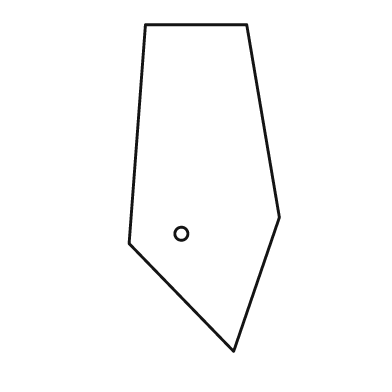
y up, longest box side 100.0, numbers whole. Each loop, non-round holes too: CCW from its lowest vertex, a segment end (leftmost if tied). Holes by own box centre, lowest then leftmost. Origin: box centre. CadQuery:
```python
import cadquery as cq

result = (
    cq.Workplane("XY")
    .moveTo(9.0, -50.0)
    .lineTo(23.0, -9.0)
    .lineTo(13.0, 50.0)
    .lineTo(-18.0, 50.0)
    .lineTo(-23.0, -17.0)
    .close()
    .moveTo(-7.0, -14.0)
    .circle(2.0)
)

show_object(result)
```